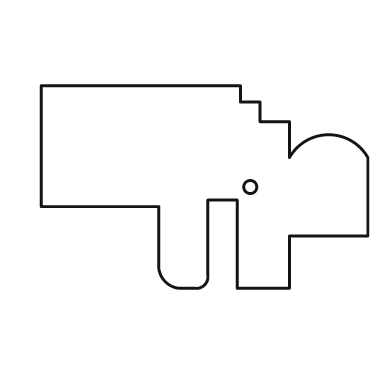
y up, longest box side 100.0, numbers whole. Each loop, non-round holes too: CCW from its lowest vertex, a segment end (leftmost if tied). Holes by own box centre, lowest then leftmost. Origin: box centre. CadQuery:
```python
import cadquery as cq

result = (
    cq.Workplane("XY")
    .moveTo(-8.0, -31.0)
    .lineTo(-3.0, -31.0)
    .threePointArc((0.0, -30.0), (1.0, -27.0))
    .lineTo(1.0, -4.0)
    .lineTo(10.0, -4.0)
    .lineTo(10.0, -31.0)
    .lineTo(26.0, -31.0)
    .lineTo(26.0, -15.0)
    .lineTo(50.0, -15.0)
    .lineTo(50.0, 9.0)
    .threePointArc((38.0, 16.0), (26.0, 9.0))
    .lineTo(26.0, 20.0)
    .lineTo(17.0, 20.0)
    .lineTo(17.0, 26.0)
    .lineTo(11.0, 26.0)
    .lineTo(11.0, 31.0)
    .lineTo(-50.0, 31.0)
    .lineTo(-50.0, -6.0)
    .lineTo(-14.0, -6.0)
    .lineTo(-14.0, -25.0)
    .threePointArc((-12.0, -29.0), (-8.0, -31.0))
    .close()
    .moveTo(14.0, 0.0)
    .circle(2.0)
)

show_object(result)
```